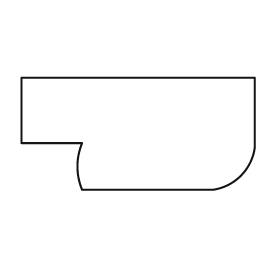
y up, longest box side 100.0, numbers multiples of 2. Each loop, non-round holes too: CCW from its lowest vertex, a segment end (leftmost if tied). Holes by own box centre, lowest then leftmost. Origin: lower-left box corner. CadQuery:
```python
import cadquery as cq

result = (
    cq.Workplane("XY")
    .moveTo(26.0, 0.0)
    .lineTo(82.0, 0.0)
    .threePointArc((94.0, 6.0), (100.0, 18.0))
    .lineTo(100.0, 48.0)
    .lineTo(0.0, 48.0)
    .lineTo(0.0, 20.0)
    .lineTo(26.0, 20.0)
    .threePointArc((24.0, 10.0), (26.0, 0.0))
    .close()
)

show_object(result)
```